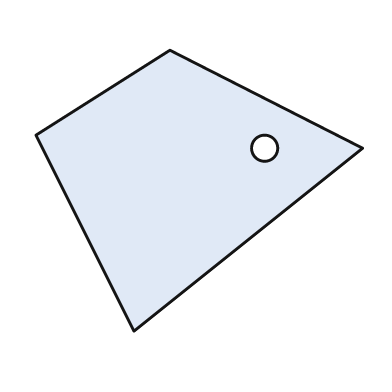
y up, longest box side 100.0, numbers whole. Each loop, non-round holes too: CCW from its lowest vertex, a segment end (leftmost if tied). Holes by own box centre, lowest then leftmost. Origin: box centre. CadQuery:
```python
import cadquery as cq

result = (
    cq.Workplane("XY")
    .moveTo(-20.0, -43.0)
    .lineTo(50.0, 13.0)
    .lineTo(-9.0, 43.0)
    .lineTo(-50.0, 17.0)
    .close()
    .moveTo(20.0, 13.0)
    .circle(4.0)
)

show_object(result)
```